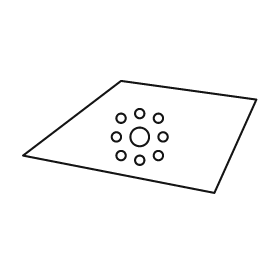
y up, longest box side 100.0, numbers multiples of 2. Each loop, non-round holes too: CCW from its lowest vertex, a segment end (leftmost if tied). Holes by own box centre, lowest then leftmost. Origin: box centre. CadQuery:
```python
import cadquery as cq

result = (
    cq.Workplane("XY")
    .moveTo(32.0, -24.0)
    .lineTo(50.0, 16.0)
    .lineTo(-8.0, 24.0)
    .lineTo(-50.0, -8.0)
    .close()
    .moveTo(0.0, -10.0)
    .circle(2.0)
    .moveTo(-8.0, -8.0)
    .circle(2.0)
    .moveTo(8.0, -8.0)
    .circle(2.0)
    .moveTo(-10.0, 0.0)
    .circle(2.0)
    .moveTo(0.0, 0.0)
    .circle(4.0)
    .moveTo(10.0, 0.0)
    .circle(2.0)
    .moveTo(-8.0, 8.0)
    .circle(2.0)
    .moveTo(8.0, 8.0)
    .circle(2.0)
    .moveTo(0.0, 10.0)
    .circle(2.0)
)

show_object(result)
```